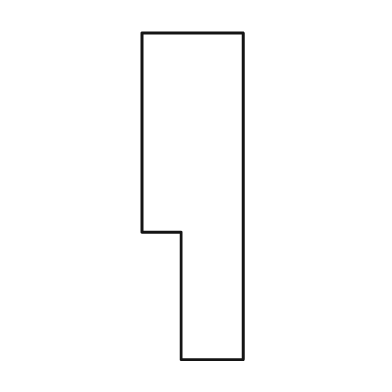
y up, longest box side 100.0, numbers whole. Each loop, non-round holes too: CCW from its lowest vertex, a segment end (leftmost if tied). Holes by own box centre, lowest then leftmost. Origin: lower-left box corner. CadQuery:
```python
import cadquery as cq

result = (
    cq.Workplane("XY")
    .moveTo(12.0, 0.0)
    .lineTo(31.0, 0.0)
    .lineTo(31.0, 100.0)
    .lineTo(0.0, 100.0)
    .lineTo(0.0, 39.0)
    .lineTo(12.0, 39.0)
    .close()
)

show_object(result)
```